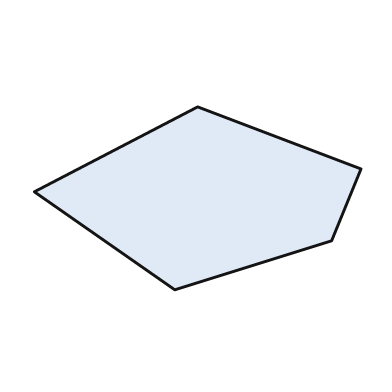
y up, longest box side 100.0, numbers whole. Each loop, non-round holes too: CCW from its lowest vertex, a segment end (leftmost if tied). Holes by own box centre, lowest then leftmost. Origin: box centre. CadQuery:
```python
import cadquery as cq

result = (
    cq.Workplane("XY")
    .moveTo(-7.0, -28.0)
    .lineTo(41.0, -13.0)
    .lineTo(50.0, 9.0)
    .lineTo(0.0, 28.0)
    .lineTo(-50.0, 2.0)
    .close()
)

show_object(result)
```